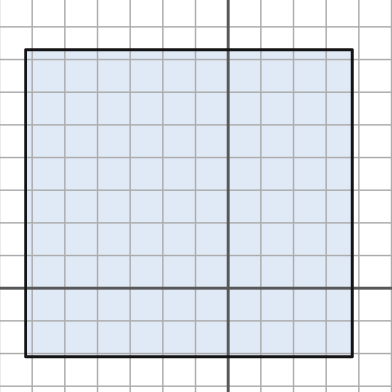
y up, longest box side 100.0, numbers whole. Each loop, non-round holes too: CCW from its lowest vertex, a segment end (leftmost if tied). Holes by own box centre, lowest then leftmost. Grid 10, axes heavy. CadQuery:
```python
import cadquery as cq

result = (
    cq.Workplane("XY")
    .moveTo(-62.0, -21.0)
    .lineTo(38.0, -21.0)
    .lineTo(38.0, 73.0)
    .lineTo(-62.0, 73.0)
    .close()
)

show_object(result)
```